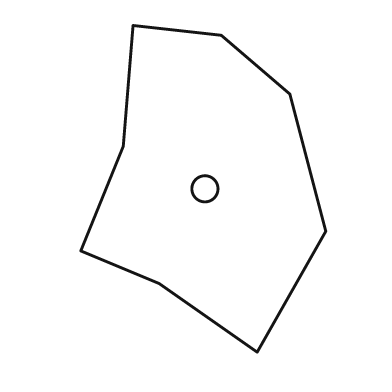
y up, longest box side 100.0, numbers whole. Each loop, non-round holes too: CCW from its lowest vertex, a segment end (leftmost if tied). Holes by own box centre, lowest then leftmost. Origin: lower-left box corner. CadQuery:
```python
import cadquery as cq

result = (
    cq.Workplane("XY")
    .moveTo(54.0, 0.0)
    .lineTo(75.0, 37.0)
    .lineTo(64.0, 79.0)
    .lineTo(43.0, 97.0)
    .lineTo(16.0, 100.0)
    .lineTo(13.0, 63.0)
    .lineTo(0.0, 31.0)
    .lineTo(24.0, 21.0)
    .close()
    .moveTo(38.0, 50.0)
    .circle(4.0)
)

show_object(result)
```